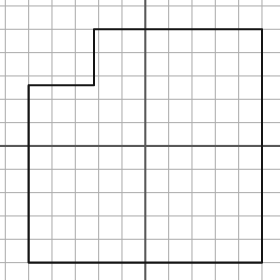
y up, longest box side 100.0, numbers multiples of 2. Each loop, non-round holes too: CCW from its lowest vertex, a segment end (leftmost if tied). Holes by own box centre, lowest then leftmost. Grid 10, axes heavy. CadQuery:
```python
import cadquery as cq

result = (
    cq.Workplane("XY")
    .moveTo(-50.0, -50.0)
    .lineTo(50.0, -50.0)
    .lineTo(50.0, 50.0)
    .lineTo(-22.0, 50.0)
    .lineTo(-22.0, 26.0)
    .lineTo(-50.0, 26.0)
    .close()
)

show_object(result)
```